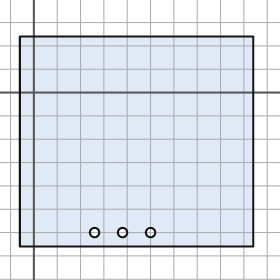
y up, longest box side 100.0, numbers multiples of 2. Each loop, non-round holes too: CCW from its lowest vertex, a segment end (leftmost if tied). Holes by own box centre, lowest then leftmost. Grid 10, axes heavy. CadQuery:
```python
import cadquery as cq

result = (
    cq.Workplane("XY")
    .moveTo(-6.0, -66.0)
    .lineTo(94.0, -66.0)
    .lineTo(94.0, 24.0)
    .lineTo(-6.0, 24.0)
    .close()
    .moveTo(26.0, -60.0)
    .circle(2.0)
    .moveTo(38.0, -60.0)
    .circle(2.0)
    .moveTo(50.0, -60.0)
    .circle(2.0)
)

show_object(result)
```